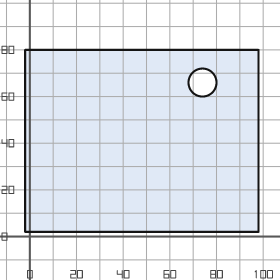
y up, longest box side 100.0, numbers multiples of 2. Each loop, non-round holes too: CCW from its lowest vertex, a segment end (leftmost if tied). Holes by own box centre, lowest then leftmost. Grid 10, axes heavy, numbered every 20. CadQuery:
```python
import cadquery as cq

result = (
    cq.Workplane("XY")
    .moveTo(-2.0, 2.0)
    .lineTo(98.0, 2.0)
    .lineTo(98.0, 80.0)
    .lineTo(-2.0, 80.0)
    .close()
    .moveTo(74.0, 66.0)
    .circle(6.0)
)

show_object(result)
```